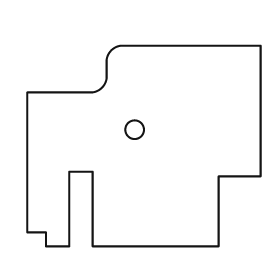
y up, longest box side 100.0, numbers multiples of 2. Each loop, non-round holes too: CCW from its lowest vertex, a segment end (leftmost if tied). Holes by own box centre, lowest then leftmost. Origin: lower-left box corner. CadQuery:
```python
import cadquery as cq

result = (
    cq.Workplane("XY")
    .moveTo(8.0, 0.0)
    .lineTo(18.0, 0.0)
    .lineTo(18.0, 32.0)
    .lineTo(28.0, 32.0)
    .lineTo(28.0, 0.0)
    .lineTo(82.0, 0.0)
    .lineTo(82.0, 30.0)
    .lineTo(100.0, 30.0)
    .lineTo(100.0, 86.0)
    .lineTo(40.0, 86.0)
    .threePointArc((36.0, 84.0), (34.0, 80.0))
    .lineTo(34.0, 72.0)
    .threePointArc((32.0, 68.0), (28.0, 66.0))
    .lineTo(0.0, 66.0)
    .lineTo(0.0, 6.0)
    .lineTo(8.0, 6.0)
    .close()
    .moveTo(46.0, 50.0)
    .circle(4.0)
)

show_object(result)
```